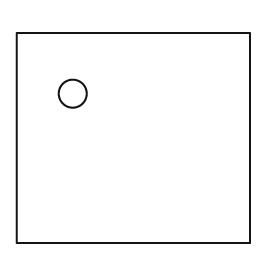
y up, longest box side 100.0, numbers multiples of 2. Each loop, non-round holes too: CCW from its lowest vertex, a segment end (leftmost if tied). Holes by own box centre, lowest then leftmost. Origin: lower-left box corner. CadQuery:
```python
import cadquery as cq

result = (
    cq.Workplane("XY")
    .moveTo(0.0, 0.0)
    .lineTo(100.0, 0.0)
    .lineTo(100.0, 90.0)
    .lineTo(0.0, 90.0)
    .close()
    .moveTo(24.0, 64.0)
    .circle(6.0)
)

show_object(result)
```